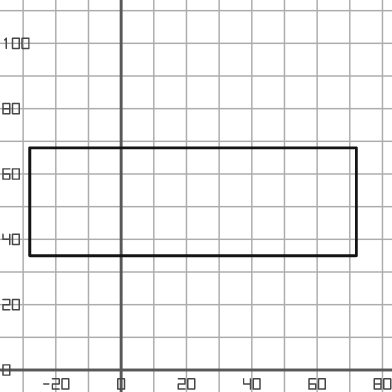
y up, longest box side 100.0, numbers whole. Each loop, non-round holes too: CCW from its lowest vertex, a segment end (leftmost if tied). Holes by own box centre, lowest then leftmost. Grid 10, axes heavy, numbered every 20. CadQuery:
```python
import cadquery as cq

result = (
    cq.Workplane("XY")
    .moveTo(-28.0, 35.0)
    .lineTo(72.0, 35.0)
    .lineTo(72.0, 68.0)
    .lineTo(-28.0, 68.0)
    .close()
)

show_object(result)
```